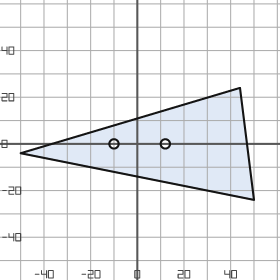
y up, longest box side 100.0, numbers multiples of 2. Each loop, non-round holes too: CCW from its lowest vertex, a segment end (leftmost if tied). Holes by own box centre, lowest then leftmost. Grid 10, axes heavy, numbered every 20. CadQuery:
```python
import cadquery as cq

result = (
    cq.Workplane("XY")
    .moveTo(50.0, -24.0)
    .lineTo(44.0, 24.0)
    .lineTo(-50.0, -4.0)
    .close()
    .moveTo(-10.0, 0.0)
    .circle(2.0)
    .moveTo(12.0, 0.0)
    .circle(2.0)
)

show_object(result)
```